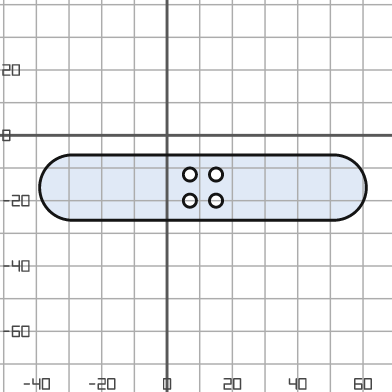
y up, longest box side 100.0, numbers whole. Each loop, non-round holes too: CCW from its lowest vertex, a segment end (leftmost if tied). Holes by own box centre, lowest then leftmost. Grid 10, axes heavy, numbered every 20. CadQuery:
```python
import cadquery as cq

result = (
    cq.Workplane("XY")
    .moveTo(-29.0, -26.0)
    .lineTo(51.0, -26.0)
    .threePointArc((61.0, -16.0), (51.0, -6.0))
    .lineTo(-29.0, -6.0)
    .threePointArc((-39.0, -16.0), (-29.0, -26.0))
    .close()
    .moveTo(7.0, -20.0)
    .circle(2.0)
    .moveTo(15.0, -20.0)
    .circle(2.0)
    .moveTo(7.0, -12.0)
    .circle(2.0)
    .moveTo(15.0, -12.0)
    .circle(2.0)
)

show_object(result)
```